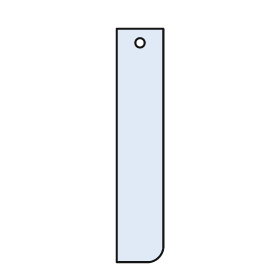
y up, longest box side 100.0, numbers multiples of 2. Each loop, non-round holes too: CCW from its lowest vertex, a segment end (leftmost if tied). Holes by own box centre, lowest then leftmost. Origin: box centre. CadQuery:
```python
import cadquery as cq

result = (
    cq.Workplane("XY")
    .moveTo(-10.0, -50.0)
    .lineTo(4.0, -50.0)
    .threePointArc((8.0, -48.0), (10.0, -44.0))
    .lineTo(10.0, 50.0)
    .lineTo(-10.0, 50.0)
    .close()
    .moveTo(0.0, 44.0)
    .circle(2.0)
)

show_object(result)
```